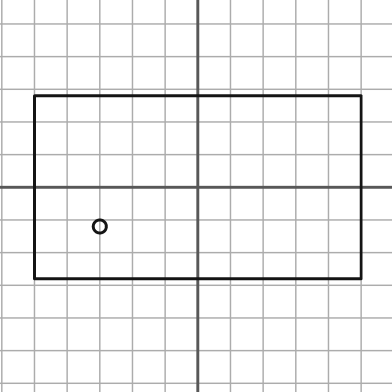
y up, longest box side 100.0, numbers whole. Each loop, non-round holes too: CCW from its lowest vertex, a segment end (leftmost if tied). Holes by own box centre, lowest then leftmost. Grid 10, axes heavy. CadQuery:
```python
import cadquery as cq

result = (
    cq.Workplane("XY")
    .moveTo(-50.0, -28.0)
    .lineTo(50.0, -28.0)
    .lineTo(50.0, 28.0)
    .lineTo(-50.0, 28.0)
    .close()
    .moveTo(-30.0, -12.0)
    .circle(2.0)
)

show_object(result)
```